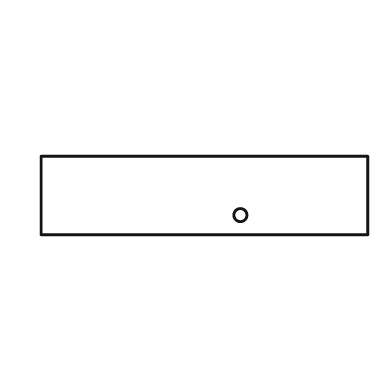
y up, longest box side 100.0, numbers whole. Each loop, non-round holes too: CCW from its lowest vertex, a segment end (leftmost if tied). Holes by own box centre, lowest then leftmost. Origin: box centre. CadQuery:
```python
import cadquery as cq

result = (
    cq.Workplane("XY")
    .moveTo(-50.0, -12.0)
    .lineTo(50.0, -12.0)
    .lineTo(50.0, 12.0)
    .lineTo(-50.0, 12.0)
    .close()
    .moveTo(11.0, -6.0)
    .circle(2.0)
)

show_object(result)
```